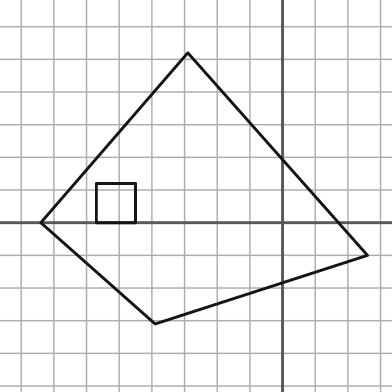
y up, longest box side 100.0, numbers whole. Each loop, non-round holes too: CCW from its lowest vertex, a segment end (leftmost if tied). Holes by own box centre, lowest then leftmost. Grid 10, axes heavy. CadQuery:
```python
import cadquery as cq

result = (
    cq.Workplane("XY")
    .moveTo(-39.0, -31.0)
    .lineTo(26.0, -10.0)
    .lineTo(-29.0, 52.0)
    .lineTo(-74.0, 0.0)
    .close()
    .moveTo(-57.0, 0.0)
    .lineTo(-45.0, 0.0)
    .lineTo(-45.0, 12.0)
    .lineTo(-57.0, 12.0)
    .close()
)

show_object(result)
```